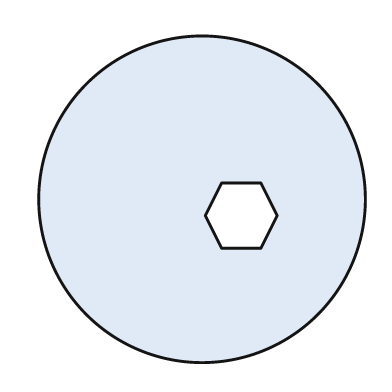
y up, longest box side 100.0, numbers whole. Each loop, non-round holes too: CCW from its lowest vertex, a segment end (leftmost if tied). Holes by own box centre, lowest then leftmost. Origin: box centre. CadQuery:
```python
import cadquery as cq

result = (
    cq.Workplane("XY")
    .moveTo(0.0, 0.0)
    .circle(50.0)
    .moveTo(6.0, -15.0)
    .lineTo(18.0, -15.0)
    .lineTo(23.0, -5.0)
    .lineTo(18.0, 5.0)
    .lineTo(6.0, 5.0)
    .lineTo(1.0, -5.0)
    .close()
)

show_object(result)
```